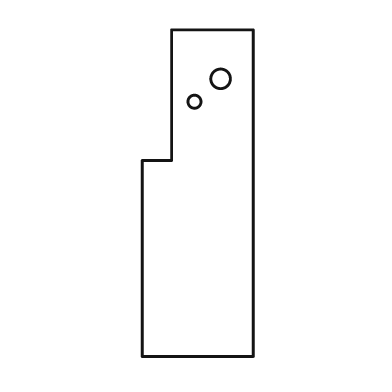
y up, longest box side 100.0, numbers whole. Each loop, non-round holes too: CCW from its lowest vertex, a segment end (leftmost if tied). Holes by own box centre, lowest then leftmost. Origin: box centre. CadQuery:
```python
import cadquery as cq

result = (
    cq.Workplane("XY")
    .moveTo(-17.0, -50.0)
    .lineTo(17.0, -50.0)
    .lineTo(17.0, 50.0)
    .lineTo(-8.0, 50.0)
    .lineTo(-8.0, 10.0)
    .lineTo(-17.0, 10.0)
    .close()
    .moveTo(-1.0, 28.0)
    .circle(2.0)
    .moveTo(7.0, 35.0)
    .circle(3.0)
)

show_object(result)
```